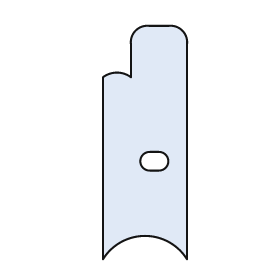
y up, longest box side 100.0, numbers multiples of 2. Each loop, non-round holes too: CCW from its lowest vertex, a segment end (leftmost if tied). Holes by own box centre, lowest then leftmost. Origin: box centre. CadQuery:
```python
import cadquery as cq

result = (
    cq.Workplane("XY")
    .moveTo(-18.0, -50.0)
    .threePointArc((0.0, -40.0), (18.0, -50.0))
    .lineTo(18.0, 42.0)
    .threePointArc((16.0, 48.0), (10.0, 50.0))
    .lineTo(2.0, 50.0)
    .threePointArc((-4.0, 48.0), (-6.0, 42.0))
    .lineTo(-6.0, 28.0)
    .threePointArc((-12.0, 30.0), (-18.0, 28.0))
    .close()
    .moveTo(2.0, -12.0)
    .lineTo(6.0, -12.0)
    .threePointArc((10.0, -8.0), (6.0, -4.0))
    .lineTo(2.0, -4.0)
    .threePointArc((-2.0, -8.0), (2.0, -12.0))
    .close()
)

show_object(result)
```